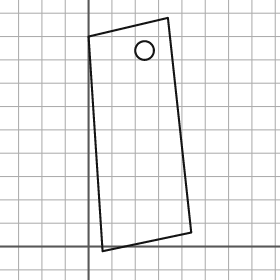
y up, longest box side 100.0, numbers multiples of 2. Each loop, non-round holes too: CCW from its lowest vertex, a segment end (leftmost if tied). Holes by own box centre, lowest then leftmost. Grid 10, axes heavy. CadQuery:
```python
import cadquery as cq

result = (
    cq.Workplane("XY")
    .moveTo(6.0, -2.0)
    .lineTo(44.0, 6.0)
    .lineTo(34.0, 98.0)
    .lineTo(0.0, 90.0)
    .close()
    .moveTo(24.0, 84.0)
    .circle(4.0)
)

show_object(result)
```